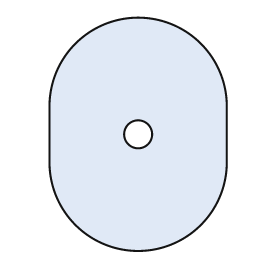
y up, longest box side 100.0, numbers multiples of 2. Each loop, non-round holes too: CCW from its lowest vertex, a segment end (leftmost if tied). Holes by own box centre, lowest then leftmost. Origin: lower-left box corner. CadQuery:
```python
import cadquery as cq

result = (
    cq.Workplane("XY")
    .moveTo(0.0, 38.0)
    .threePointArc((38.0, 0.0), (76.0, 38.0))
    .lineTo(76.0, 62.0)
    .threePointArc((38.0, 100.0), (0.0, 62.0))
    .close()
    .moveTo(38.0, 50.0)
    .circle(6.0)
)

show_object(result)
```